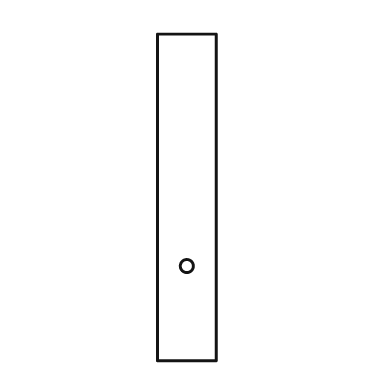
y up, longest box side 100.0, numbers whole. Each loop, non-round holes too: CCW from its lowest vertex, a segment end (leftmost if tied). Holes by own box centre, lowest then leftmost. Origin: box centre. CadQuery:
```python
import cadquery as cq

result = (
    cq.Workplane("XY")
    .moveTo(-9.0, -50.0)
    .lineTo(9.0, -50.0)
    .lineTo(9.0, 50.0)
    .lineTo(-9.0, 50.0)
    .close()
    .moveTo(0.0, -21.0)
    .circle(2.0)
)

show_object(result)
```